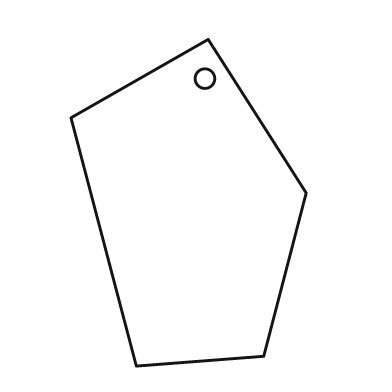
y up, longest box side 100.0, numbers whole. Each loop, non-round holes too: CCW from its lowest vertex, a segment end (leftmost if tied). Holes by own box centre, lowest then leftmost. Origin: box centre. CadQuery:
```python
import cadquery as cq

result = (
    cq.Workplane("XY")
    .moveTo(-16.0, -50.0)
    .lineTo(23.0, -47.0)
    .lineTo(36.0, 3.0)
    .lineTo(6.0, 50.0)
    .lineTo(-36.0, 26.0)
    .close()
    .moveTo(5.0, 38.0)
    .circle(3.0)
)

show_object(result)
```